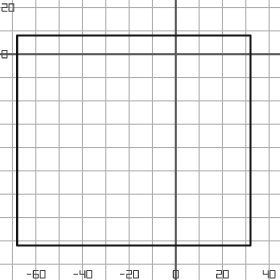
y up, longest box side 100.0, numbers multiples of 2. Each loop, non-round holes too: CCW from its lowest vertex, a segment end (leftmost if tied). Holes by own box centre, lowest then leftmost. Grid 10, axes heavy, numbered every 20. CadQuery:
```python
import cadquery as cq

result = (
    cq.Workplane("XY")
    .moveTo(-68.0, -82.0)
    .lineTo(32.0, -82.0)
    .lineTo(32.0, 8.0)
    .lineTo(-68.0, 8.0)
    .close()
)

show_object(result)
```